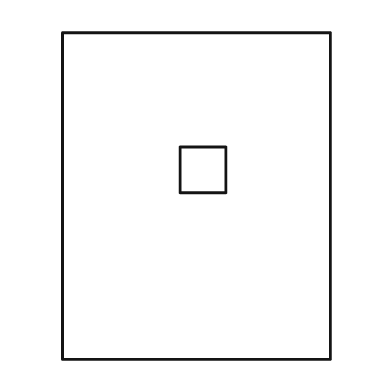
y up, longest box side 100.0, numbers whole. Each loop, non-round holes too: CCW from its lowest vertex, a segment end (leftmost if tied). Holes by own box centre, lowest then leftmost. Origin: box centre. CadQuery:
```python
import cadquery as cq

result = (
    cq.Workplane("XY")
    .moveTo(-41.0, -50.0)
    .lineTo(41.0, -50.0)
    .lineTo(41.0, 50.0)
    .lineTo(-41.0, 50.0)
    .close()
    .moveTo(-5.0, 1.0)
    .lineTo(9.0, 1.0)
    .lineTo(9.0, 15.0)
    .lineTo(-5.0, 15.0)
    .close()
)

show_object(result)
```